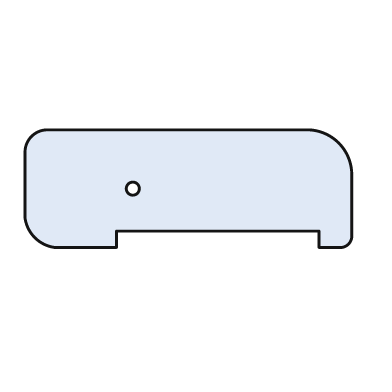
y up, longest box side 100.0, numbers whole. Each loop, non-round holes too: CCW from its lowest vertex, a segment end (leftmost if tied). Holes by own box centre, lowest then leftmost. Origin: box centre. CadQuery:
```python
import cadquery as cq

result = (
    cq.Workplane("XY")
    .moveTo(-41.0, -18.0)
    .lineTo(-22.0, -18.0)
    .lineTo(-22.0, -13.0)
    .lineTo(40.0, -13.0)
    .lineTo(40.0, -18.0)
    .lineTo(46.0, -18.0)
    .threePointArc((49.0, -17.0), (50.0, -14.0))
    .lineTo(50.0, 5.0)
    .threePointArc((46.0, 14.0), (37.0, 18.0))
    .lineTo(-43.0, 18.0)
    .threePointArc((-48.0, 16.0), (-50.0, 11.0))
    .lineTo(-50.0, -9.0)
    .threePointArc((-47.0, -15.0), (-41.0, -18.0))
    .close()
    .moveTo(-17.0, 0.0)
    .circle(2.0)
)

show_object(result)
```